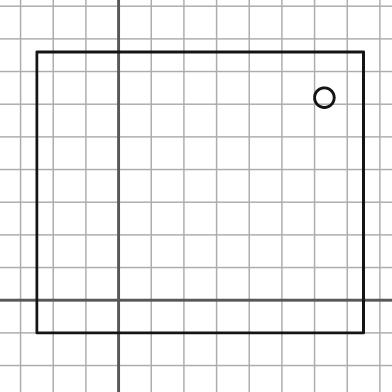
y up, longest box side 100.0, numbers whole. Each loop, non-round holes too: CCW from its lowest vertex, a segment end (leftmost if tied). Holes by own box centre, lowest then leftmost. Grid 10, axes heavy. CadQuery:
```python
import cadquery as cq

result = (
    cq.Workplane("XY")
    .moveTo(-25.0, -10.0)
    .lineTo(75.0, -10.0)
    .lineTo(75.0, 76.0)
    .lineTo(-25.0, 76.0)
    .close()
    .moveTo(63.0, 62.0)
    .circle(3.0)
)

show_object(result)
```